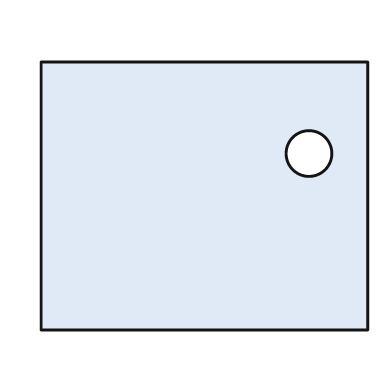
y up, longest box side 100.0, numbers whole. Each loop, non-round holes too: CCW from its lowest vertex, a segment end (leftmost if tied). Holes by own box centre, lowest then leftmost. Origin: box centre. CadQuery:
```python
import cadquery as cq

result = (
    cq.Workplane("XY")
    .moveTo(-50.0, -41.0)
    .lineTo(50.0, -41.0)
    .lineTo(50.0, 41.0)
    .lineTo(-50.0, 41.0)
    .close()
    .moveTo(32.0, 13.0)
    .circle(7.0)
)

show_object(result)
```